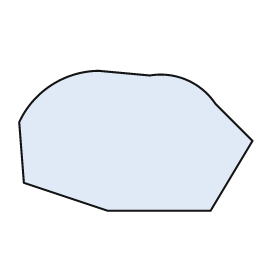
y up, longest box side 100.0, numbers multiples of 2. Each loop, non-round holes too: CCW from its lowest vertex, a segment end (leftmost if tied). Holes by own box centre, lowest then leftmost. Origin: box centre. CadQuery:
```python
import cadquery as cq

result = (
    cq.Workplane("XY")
    .moveTo(-12.0, -30.0)
    .lineTo(32.0, -30.0)
    .lineTo(50.0, 0.0)
    .lineTo(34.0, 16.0)
    .threePointArc((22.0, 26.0), (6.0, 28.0))
    .lineTo(-16.0, 30.0)
    .threePointArc((-36.0, 24.0), (-50.0, 8.0))
    .lineTo(-48.0, -18.0)
    .close()
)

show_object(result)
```